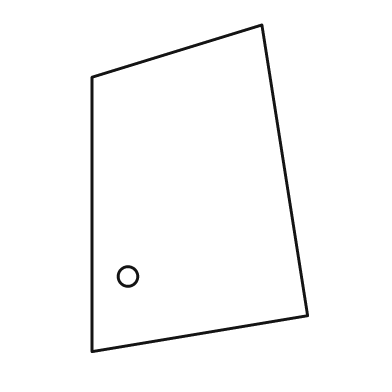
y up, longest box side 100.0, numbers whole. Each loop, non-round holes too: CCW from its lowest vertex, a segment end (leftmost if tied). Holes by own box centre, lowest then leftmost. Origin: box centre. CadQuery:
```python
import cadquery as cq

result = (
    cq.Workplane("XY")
    .moveTo(-33.0, -50.0)
    .lineTo(33.0, -39.0)
    .lineTo(19.0, 50.0)
    .lineTo(-33.0, 34.0)
    .close()
    .moveTo(-22.0, -27.0)
    .circle(3.0)
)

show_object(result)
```